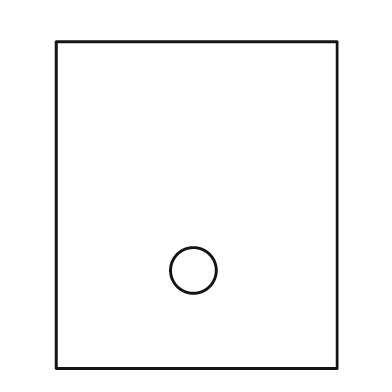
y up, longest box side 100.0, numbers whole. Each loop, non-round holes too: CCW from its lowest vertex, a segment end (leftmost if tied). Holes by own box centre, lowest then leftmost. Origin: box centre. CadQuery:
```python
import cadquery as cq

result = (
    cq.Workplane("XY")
    .moveTo(-43.0, -50.0)
    .lineTo(43.0, -50.0)
    .lineTo(43.0, 50.0)
    .lineTo(-43.0, 50.0)
    .close()
    .moveTo(-1.0, -20.0)
    .circle(7.0)
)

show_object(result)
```